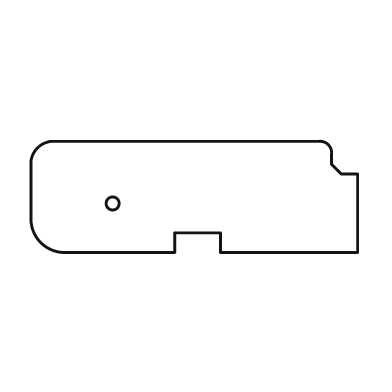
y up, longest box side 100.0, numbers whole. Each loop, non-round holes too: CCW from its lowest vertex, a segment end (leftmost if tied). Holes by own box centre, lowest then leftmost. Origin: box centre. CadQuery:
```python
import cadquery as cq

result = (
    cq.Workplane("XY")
    .moveTo(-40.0, -17.0)
    .lineTo(-6.0, -17.0)
    .lineTo(-6.0, -11.0)
    .lineTo(8.0, -11.0)
    .lineTo(8.0, -17.0)
    .lineTo(50.0, -17.0)
    .lineTo(50.0, 7.0)
    .lineTo(45.0, 7.0)
    .lineTo(42.0, 10.0)
    .lineTo(42.0, 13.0)
    .threePointArc((41.0, 16.0), (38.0, 17.0))
    .lineTo(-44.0, 17.0)
    .threePointArc((-48.0, 15.0), (-50.0, 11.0))
    .lineTo(-50.0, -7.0)
    .threePointArc((-47.0, -14.0), (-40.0, -17.0))
    .close()
    .moveTo(-25.0, -2.0)
    .circle(2.0)
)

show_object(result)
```